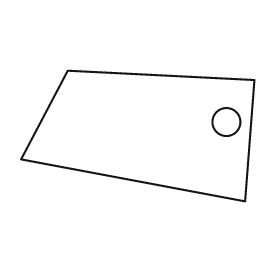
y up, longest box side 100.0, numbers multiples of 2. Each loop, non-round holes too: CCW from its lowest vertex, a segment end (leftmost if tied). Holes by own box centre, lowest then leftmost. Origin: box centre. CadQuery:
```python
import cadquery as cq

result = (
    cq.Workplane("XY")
    .moveTo(46.0, -28.0)
    .lineTo(50.0, 24.0)
    .lineTo(-30.0, 28.0)
    .lineTo(-50.0, -10.0)
    .close()
    .moveTo(38.0, 6.0)
    .circle(6.0)
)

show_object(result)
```